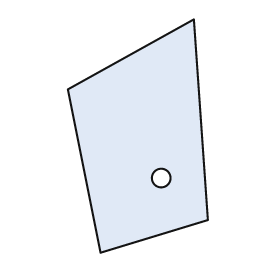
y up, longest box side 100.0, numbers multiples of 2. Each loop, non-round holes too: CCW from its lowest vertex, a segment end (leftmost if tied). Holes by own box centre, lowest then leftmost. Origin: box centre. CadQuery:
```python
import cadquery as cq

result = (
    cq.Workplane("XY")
    .moveTo(-16.0, -50.0)
    .lineTo(30.0, -36.0)
    .lineTo(24.0, 50.0)
    .lineTo(-30.0, 20.0)
    .close()
    .moveTo(10.0, -18.0)
    .circle(4.0)
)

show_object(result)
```